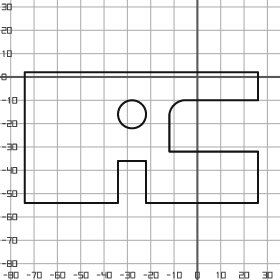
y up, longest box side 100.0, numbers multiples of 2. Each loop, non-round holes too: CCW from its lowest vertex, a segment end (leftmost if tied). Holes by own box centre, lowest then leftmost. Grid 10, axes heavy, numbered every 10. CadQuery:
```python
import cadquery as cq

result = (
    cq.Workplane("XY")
    .moveTo(-74.0, -54.0)
    .lineTo(-34.0, -54.0)
    .lineTo(-34.0, -36.0)
    .lineTo(-22.0, -36.0)
    .lineTo(-22.0, -54.0)
    .lineTo(26.0, -54.0)
    .lineTo(26.0, -32.0)
    .lineTo(-12.0, -32.0)
    .lineTo(-12.0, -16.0)
    .threePointArc((-10.0, -12.0), (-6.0, -10.0))
    .lineTo(26.0, -10.0)
    .lineTo(26.0, 2.0)
    .lineTo(-74.0, 2.0)
    .close()
    .moveTo(-28.0, -16.0)
    .circle(6.0)
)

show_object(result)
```